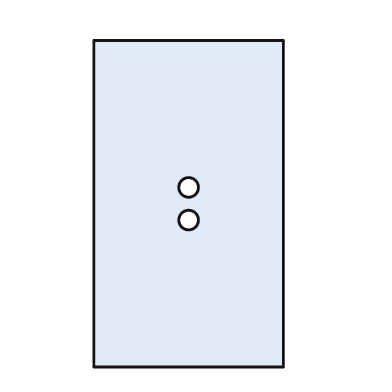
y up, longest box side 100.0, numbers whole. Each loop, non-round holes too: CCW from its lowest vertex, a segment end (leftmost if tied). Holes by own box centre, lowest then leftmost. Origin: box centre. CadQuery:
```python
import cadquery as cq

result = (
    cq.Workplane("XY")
    .moveTo(-29.0, -50.0)
    .lineTo(29.0, -50.0)
    .lineTo(29.0, 50.0)
    .lineTo(-29.0, 50.0)
    .close()
    .moveTo(0.0, -5.0)
    .circle(3.0)
    .moveTo(0.0, 5.0)
    .circle(3.0)
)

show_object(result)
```